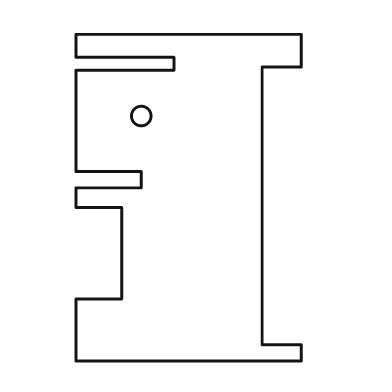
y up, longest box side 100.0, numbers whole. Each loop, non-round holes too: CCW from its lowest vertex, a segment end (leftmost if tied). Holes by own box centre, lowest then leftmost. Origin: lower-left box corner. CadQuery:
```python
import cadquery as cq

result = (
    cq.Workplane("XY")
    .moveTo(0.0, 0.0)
    .lineTo(69.0, 0.0)
    .lineTo(69.0, 5.0)
    .lineTo(57.0, 5.0)
    .lineTo(57.0, 90.0)
    .lineTo(69.0, 90.0)
    .lineTo(69.0, 100.0)
    .lineTo(0.0, 100.0)
    .lineTo(0.0, 93.0)
    .lineTo(30.0, 93.0)
    .lineTo(30.0, 89.0)
    .lineTo(0.0, 89.0)
    .lineTo(0.0, 58.0)
    .lineTo(20.0, 58.0)
    .lineTo(20.0, 53.0)
    .lineTo(0.0, 53.0)
    .lineTo(0.0, 47.0)
    .lineTo(14.0, 47.0)
    .lineTo(14.0, 19.0)
    .lineTo(0.0, 19.0)
    .close()
    .moveTo(20.0, 75.0)
    .circle(3.0)
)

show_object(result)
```